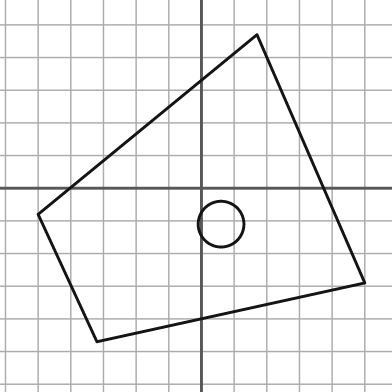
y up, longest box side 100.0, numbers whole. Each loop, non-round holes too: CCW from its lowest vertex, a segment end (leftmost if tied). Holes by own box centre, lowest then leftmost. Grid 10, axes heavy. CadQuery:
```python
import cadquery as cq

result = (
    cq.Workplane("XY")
    .moveTo(-32.0, -47.0)
    .lineTo(50.0, -29.0)
    .lineTo(17.0, 47.0)
    .lineTo(-50.0, -8.0)
    .close()
    .moveTo(6.0, -11.0)
    .circle(7.0)
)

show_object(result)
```